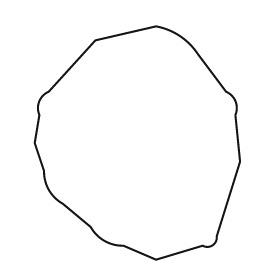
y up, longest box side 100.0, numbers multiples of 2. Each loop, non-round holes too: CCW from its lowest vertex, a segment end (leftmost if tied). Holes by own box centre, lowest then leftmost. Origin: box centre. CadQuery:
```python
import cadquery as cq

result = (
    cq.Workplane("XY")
    .moveTo(8.0, -50.0)
    .lineTo(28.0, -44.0)
    .threePointArc((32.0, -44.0), (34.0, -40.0))
    .lineTo(44.0, -8.0)
    .lineTo(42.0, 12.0)
    .threePointArc((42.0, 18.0), (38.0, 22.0))
    .lineTo(26.0, 38.0)
    .threePointArc((18.0, 46.0), (8.0, 50.0))
    .lineTo(-18.0, 44.0)
    .lineTo(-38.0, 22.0)
    .threePointArc((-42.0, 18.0), (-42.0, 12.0))
    .lineTo(-44.0, 0.0)
    .lineTo(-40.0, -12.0)
    .threePointArc((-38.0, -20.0), (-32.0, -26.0))
    .lineTo(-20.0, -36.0)
    .threePointArc((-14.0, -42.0), (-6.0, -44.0))
    .close()
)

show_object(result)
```